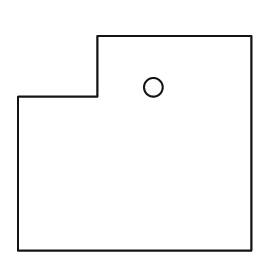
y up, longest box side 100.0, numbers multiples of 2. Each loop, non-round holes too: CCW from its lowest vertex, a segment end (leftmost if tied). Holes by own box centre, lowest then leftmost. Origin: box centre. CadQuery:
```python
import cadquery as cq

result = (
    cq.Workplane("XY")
    .moveTo(-50.0, -46.0)
    .lineTo(50.0, -46.0)
    .lineTo(50.0, 46.0)
    .lineTo(-16.0, 46.0)
    .lineTo(-16.0, 20.0)
    .lineTo(-50.0, 20.0)
    .close()
    .moveTo(8.0, 24.0)
    .circle(4.0)
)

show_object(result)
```